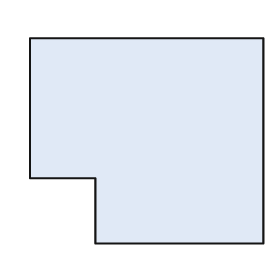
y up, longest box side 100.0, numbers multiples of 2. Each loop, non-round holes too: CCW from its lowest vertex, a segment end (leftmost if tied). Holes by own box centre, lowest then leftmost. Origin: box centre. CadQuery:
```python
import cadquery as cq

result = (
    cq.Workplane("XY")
    .moveTo(-22.0, -44.0)
    .lineTo(50.0, -44.0)
    .lineTo(50.0, 44.0)
    .lineTo(-50.0, 44.0)
    .lineTo(-50.0, -16.0)
    .lineTo(-22.0, -16.0)
    .close()
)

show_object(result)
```